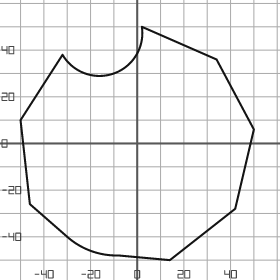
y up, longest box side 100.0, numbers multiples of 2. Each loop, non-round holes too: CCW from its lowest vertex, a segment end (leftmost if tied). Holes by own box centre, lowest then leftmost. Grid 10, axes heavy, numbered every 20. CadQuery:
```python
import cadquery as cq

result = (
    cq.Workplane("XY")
    .moveTo(14.0, -50.0)
    .lineTo(42.0, -28.0)
    .lineTo(50.0, 6.0)
    .lineTo(34.0, 36.0)
    .lineTo(2.0, 50.0)
    .threePointArc((-10.0, 30.0), (-32.0, 38.0))
    .lineTo(-50.0, 10.0)
    .lineTo(-46.0, -26.0)
    .lineTo(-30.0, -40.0)
    .threePointArc((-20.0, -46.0), (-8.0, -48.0))
    .close()
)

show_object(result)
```